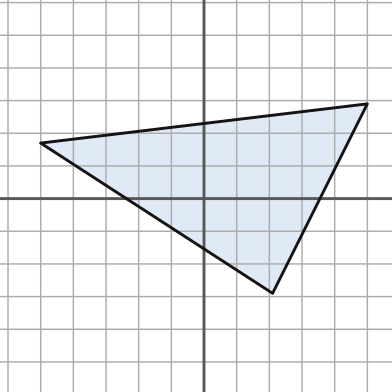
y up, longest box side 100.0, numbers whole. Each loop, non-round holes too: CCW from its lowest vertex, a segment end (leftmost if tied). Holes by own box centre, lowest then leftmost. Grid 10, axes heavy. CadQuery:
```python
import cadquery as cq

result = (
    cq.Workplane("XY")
    .moveTo(21.0, -29.0)
    .lineTo(50.0, 29.0)
    .lineTo(-50.0, 17.0)
    .close()
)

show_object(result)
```